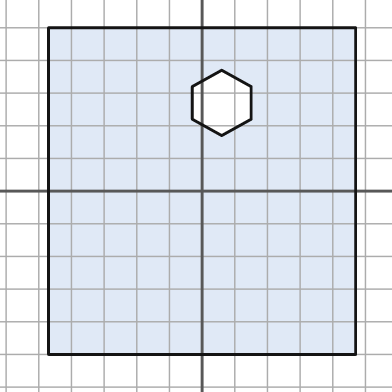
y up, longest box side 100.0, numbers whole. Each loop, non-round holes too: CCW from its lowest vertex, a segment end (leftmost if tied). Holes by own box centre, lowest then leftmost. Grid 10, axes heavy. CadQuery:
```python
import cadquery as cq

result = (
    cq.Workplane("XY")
    .moveTo(-47.0, -50.0)
    .lineTo(47.0, -50.0)
    .lineTo(47.0, 50.0)
    .lineTo(-47.0, 50.0)
    .close()
    .moveTo(6.0, 17.0)
    .lineTo(15.0, 22.0)
    .lineTo(15.0, 32.0)
    .lineTo(6.0, 37.0)
    .lineTo(-3.0, 32.0)
    .lineTo(-3.0, 22.0)
    .close()
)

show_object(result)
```